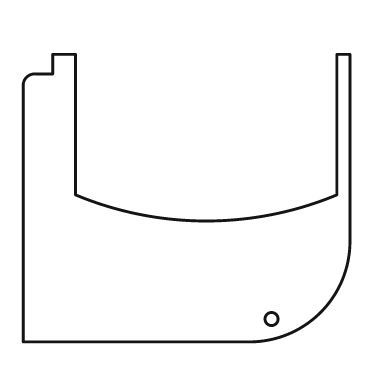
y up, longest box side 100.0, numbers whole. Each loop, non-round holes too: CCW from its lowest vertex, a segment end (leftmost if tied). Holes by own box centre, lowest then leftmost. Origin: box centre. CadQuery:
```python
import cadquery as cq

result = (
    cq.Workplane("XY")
    .moveTo(-50.0, -44.0)
    .lineTo(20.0, -44.0)
    .threePointArc((41.0, -35.0), (50.0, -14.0))
    .lineTo(50.0, 44.0)
    .lineTo(46.0, 44.0)
    .lineTo(46.0, 1.0)
    .threePointArc((6.0, -7.0), (-34.0, 1.0))
    .lineTo(-34.0, 44.0)
    .lineTo(-41.0, 44.0)
    .lineTo(-41.0, 38.0)
    .lineTo(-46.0, 38.0)
    .threePointArc((-49.0, 37.0), (-50.0, 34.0))
    .close()
    .moveTo(26.0, -37.0)
    .circle(2.0)
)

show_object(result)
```